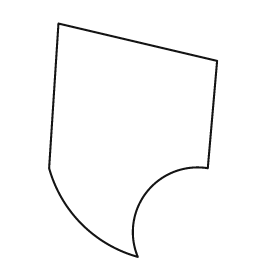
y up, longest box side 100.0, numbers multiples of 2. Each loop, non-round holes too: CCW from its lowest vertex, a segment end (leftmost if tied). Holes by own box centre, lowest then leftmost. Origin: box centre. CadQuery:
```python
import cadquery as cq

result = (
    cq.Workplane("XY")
    .moveTo(2.0, -50.0)
    .threePointArc((6.0, -22.0), (32.0, -12.0))
    .lineTo(36.0, 34.0)
    .lineTo(-32.0, 50.0)
    .lineTo(-36.0, -12.0)
    .threePointArc((-22.0, -36.0), (2.0, -50.0))
    .close()
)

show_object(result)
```